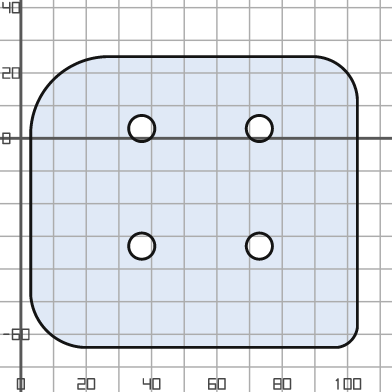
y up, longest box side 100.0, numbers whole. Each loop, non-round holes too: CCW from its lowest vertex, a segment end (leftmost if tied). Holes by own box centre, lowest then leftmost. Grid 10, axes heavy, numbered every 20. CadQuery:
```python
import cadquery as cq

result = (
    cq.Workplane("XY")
    .moveTo(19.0, -64.0)
    .lineTo(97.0, -64.0)
    .threePointArc((101.0, -62.0), (103.0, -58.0))
    .lineTo(103.0, 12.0)
    .threePointArc((99.0, 21.0), (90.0, 25.0))
    .lineTo(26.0, 25.0)
    .threePointArc((10.0, 18.0), (3.0, 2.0))
    .lineTo(3.0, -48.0)
    .threePointArc((8.0, -59.0), (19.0, -64.0))
    .close()
    .moveTo(37.0, -33.0)
    .circle(4.0)
    .moveTo(73.0, -33.0)
    .circle(4.0)
    .moveTo(37.0, 3.0)
    .circle(4.0)
    .moveTo(73.0, 3.0)
    .circle(4.0)
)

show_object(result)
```